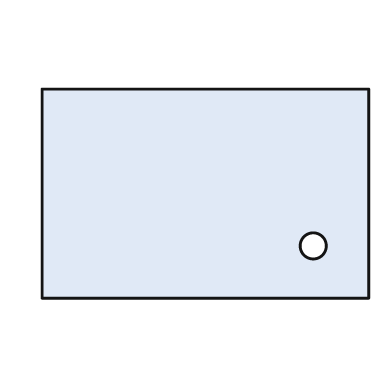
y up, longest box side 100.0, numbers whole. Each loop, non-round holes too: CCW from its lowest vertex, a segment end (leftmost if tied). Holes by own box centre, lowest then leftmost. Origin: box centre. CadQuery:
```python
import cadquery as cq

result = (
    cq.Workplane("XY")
    .moveTo(-50.0, -32.0)
    .lineTo(50.0, -32.0)
    .lineTo(50.0, 32.0)
    .lineTo(-50.0, 32.0)
    .close()
    .moveTo(33.0, -16.0)
    .circle(4.0)
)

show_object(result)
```